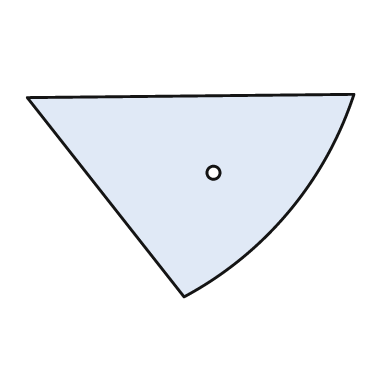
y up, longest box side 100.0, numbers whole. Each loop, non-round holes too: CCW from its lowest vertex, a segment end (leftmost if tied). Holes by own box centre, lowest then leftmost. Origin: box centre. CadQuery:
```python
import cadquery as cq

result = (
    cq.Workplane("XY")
    .moveTo(-2.0, -31.0)
    .threePointArc((30.0, -5.0), (50.0, 31.0))
    .lineTo(-50.0, 30.0)
    .close()
    .moveTo(7.0, 7.0)
    .circle(2.0)
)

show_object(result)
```